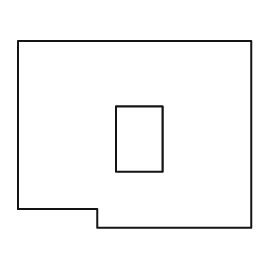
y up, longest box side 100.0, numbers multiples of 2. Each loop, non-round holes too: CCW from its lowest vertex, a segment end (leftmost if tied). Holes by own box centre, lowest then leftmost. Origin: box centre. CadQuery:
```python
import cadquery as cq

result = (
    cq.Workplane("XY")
    .moveTo(-16.0, -40.0)
    .lineTo(50.0, -40.0)
    .lineTo(50.0, 40.0)
    .lineTo(-50.0, 40.0)
    .lineTo(-50.0, -32.0)
    .lineTo(-16.0, -32.0)
    .close()
    .moveTo(-8.0, -16.0)
    .lineTo(12.0, -16.0)
    .lineTo(12.0, 12.0)
    .lineTo(-8.0, 12.0)
    .close()
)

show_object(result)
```